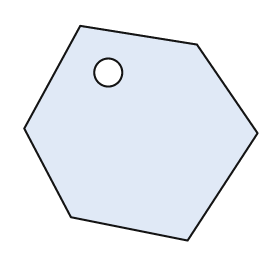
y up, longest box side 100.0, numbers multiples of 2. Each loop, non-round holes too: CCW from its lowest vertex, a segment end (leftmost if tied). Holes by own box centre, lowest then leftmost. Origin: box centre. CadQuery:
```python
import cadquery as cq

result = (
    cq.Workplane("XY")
    .moveTo(20.0, -46.0)
    .lineTo(50.0, 0.0)
    .lineTo(24.0, 38.0)
    .lineTo(-26.0, 46.0)
    .lineTo(-50.0, 2.0)
    .lineTo(-30.0, -36.0)
    .close()
    .moveTo(-14.0, 26.0)
    .circle(6.0)
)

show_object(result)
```